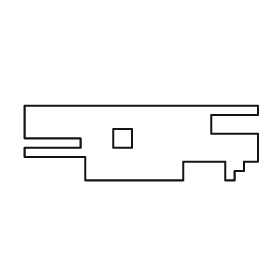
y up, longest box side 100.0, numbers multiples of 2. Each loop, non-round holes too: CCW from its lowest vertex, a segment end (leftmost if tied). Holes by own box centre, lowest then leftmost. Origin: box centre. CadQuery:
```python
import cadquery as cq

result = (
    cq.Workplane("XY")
    .moveTo(-24.0, -16.0)
    .lineTo(18.0, -16.0)
    .lineTo(18.0, -8.0)
    .lineTo(36.0, -8.0)
    .lineTo(36.0, -16.0)
    .lineTo(40.0, -16.0)
    .lineTo(40.0, -12.0)
    .lineTo(44.0, -12.0)
    .lineTo(44.0, -8.0)
    .lineTo(50.0, -8.0)
    .lineTo(50.0, 4.0)
    .lineTo(30.0, 4.0)
    .lineTo(30.0, 12.0)
    .lineTo(50.0, 12.0)
    .lineTo(50.0, 16.0)
    .lineTo(-50.0, 16.0)
    .lineTo(-50.0, 2.0)
    .lineTo(-26.0, 2.0)
    .lineTo(-26.0, -2.0)
    .lineTo(-50.0, -2.0)
    .lineTo(-50.0, -6.0)
    .lineTo(-24.0, -6.0)
    .close()
    .moveTo(-12.0, -2.0)
    .lineTo(-4.0, -2.0)
    .lineTo(-4.0, 6.0)
    .lineTo(-12.0, 6.0)
    .close()
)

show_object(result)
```